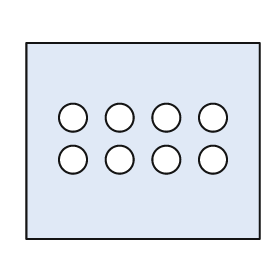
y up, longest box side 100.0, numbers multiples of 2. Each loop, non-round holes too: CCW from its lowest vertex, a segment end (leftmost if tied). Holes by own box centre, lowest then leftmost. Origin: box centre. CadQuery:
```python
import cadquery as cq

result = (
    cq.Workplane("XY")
    .moveTo(-50.0, -42.0)
    .lineTo(50.0, -42.0)
    .lineTo(50.0, 42.0)
    .lineTo(-50.0, 42.0)
    .close()
    .moveTo(-30.0, -8.0)
    .circle(6.0)
    .moveTo(-10.0, -8.0)
    .circle(6.0)
    .moveTo(10.0, -8.0)
    .circle(6.0)
    .moveTo(30.0, -8.0)
    .circle(6.0)
    .moveTo(-30.0, 10.0)
    .circle(6.0)
    .moveTo(-10.0, 10.0)
    .circle(6.0)
    .moveTo(10.0, 10.0)
    .circle(6.0)
    .moveTo(30.0, 10.0)
    .circle(6.0)
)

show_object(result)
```